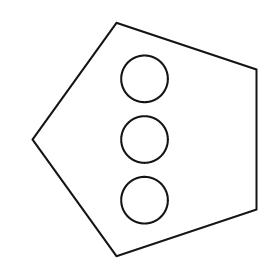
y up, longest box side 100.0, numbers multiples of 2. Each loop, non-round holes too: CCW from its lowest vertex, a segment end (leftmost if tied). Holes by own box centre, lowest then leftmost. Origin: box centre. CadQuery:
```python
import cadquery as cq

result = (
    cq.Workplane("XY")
    .moveTo(-12.0, -50.0)
    .lineTo(48.0, -30.0)
    .lineTo(48.0, 30.0)
    .lineTo(-12.0, 50.0)
    .lineTo(-48.0, 0.0)
    .close()
    .moveTo(0.0, -26.0)
    .circle(10.0)
    .moveTo(0.0, 0.0)
    .circle(10.0)
    .moveTo(0.0, 26.0)
    .circle(10.0)
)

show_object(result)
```